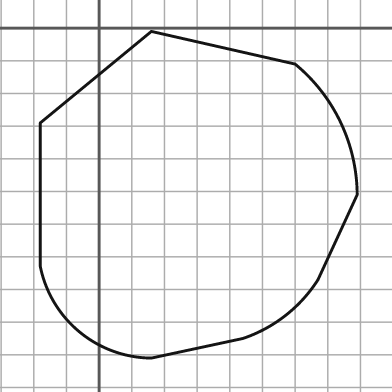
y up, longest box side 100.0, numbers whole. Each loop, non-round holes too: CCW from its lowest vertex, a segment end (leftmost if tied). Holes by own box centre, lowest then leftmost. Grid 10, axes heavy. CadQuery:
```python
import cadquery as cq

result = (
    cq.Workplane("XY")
    .moveTo(16.0, -101.0)
    .lineTo(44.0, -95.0)
    .threePointArc((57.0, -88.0), (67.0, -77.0))
    .lineTo(79.0, -51.0)
    .threePointArc((74.0, -29.0), (60.0, -11.0))
    .lineTo(16.0, -1.0)
    .lineTo(-18.0, -29.0)
    .lineTo(-18.0, -73.0)
    .threePointArc((-6.0, -93.0), (16.0, -101.0))
    .close()
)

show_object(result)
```